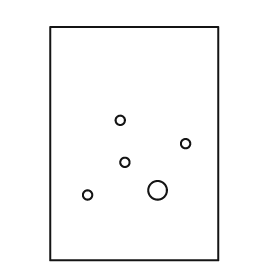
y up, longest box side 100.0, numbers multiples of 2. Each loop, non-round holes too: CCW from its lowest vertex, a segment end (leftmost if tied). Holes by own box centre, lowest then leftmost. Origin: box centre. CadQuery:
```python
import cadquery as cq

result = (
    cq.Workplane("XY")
    .moveTo(-36.0, -50.0)
    .lineTo(36.0, -50.0)
    .lineTo(36.0, 50.0)
    .lineTo(-36.0, 50.0)
    .close()
    .moveTo(-20.0, -22.0)
    .circle(2.0)
    .moveTo(10.0, -20.0)
    .circle(4.0)
    .moveTo(-4.0, -8.0)
    .circle(2.0)
    .moveTo(22.0, 0.0)
    .circle(2.0)
    .moveTo(-6.0, 10.0)
    .circle(2.0)
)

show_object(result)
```